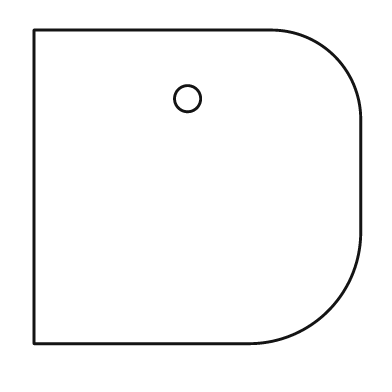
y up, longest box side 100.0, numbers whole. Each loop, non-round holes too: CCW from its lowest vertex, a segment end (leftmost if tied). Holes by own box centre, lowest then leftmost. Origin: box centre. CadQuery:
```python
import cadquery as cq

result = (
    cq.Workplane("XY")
    .moveTo(-50.0, -48.0)
    .lineTo(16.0, -48.0)
    .threePointArc((40.0, -38.0), (50.0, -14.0))
    .lineTo(50.0, 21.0)
    .threePointArc((42.0, 40.0), (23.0, 48.0))
    .lineTo(-50.0, 48.0)
    .close()
    .moveTo(-3.0, 27.0)
    .circle(4.0)
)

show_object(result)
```